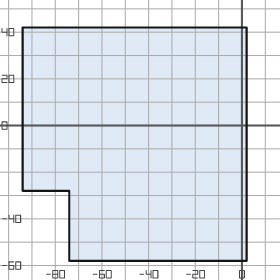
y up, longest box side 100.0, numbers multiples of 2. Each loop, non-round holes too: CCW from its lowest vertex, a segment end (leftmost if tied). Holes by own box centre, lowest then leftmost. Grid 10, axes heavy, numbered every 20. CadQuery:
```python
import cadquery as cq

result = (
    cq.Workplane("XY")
    .moveTo(-74.0, -58.0)
    .lineTo(2.0, -58.0)
    .lineTo(2.0, 42.0)
    .lineTo(-94.0, 42.0)
    .lineTo(-94.0, -28.0)
    .lineTo(-74.0, -28.0)
    .close()
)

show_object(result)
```